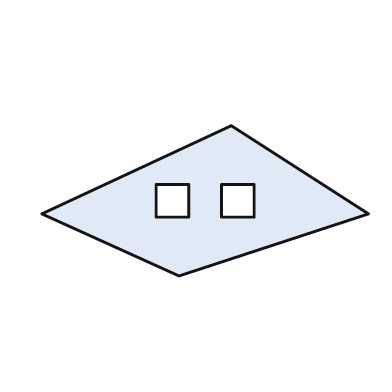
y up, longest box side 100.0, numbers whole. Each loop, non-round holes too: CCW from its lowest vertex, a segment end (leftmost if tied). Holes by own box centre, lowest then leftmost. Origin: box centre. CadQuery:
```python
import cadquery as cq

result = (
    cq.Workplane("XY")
    .moveTo(-8.0, -23.0)
    .lineTo(50.0, -4.0)
    .lineTo(8.0, 23.0)
    .lineTo(-50.0, -4.0)
    .close()
    .moveTo(-15.0, -5.0)
    .lineTo(-5.0, -5.0)
    .lineTo(-5.0, 5.0)
    .lineTo(-15.0, 5.0)
    .close()
    .moveTo(5.0, -5.0)
    .lineTo(15.0, -5.0)
    .lineTo(15.0, 5.0)
    .lineTo(5.0, 5.0)
    .close()
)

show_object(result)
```